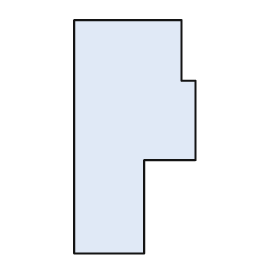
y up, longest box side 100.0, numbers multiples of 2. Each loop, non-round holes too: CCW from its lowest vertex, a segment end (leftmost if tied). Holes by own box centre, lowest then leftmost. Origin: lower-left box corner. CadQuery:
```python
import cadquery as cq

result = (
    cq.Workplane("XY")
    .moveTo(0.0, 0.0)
    .lineTo(30.0, 0.0)
    .lineTo(30.0, 40.0)
    .lineTo(52.0, 40.0)
    .lineTo(52.0, 74.0)
    .lineTo(46.0, 74.0)
    .lineTo(46.0, 100.0)
    .lineTo(0.0, 100.0)
    .close()
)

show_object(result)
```